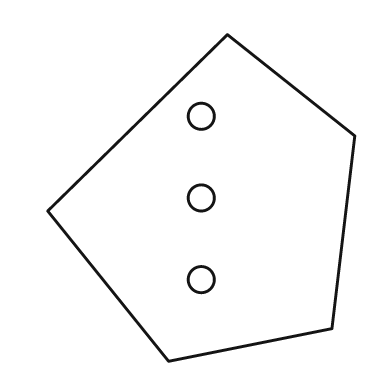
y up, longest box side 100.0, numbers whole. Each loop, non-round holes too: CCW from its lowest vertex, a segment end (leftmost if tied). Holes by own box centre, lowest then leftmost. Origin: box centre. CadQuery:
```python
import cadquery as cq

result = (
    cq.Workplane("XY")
    .moveTo(-10.0, -50.0)
    .lineTo(40.0, -40.0)
    .lineTo(47.0, 19.0)
    .lineTo(8.0, 50.0)
    .lineTo(-47.0, -4.0)
    .close()
    .moveTo(0.0, -25.0)
    .circle(4.0)
    .moveTo(0.0, 0.0)
    .circle(4.0)
    .moveTo(0.0, 25.0)
    .circle(4.0)
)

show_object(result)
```